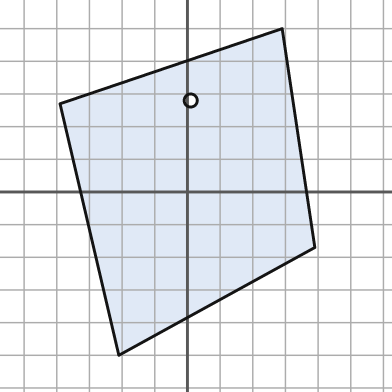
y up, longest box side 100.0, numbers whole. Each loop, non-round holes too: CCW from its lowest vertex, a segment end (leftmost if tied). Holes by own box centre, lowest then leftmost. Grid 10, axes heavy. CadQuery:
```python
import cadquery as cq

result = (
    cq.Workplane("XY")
    .moveTo(-21.0, -50.0)
    .lineTo(39.0, -17.0)
    .lineTo(29.0, 50.0)
    .lineTo(-39.0, 27.0)
    .close()
    .moveTo(1.0, 28.0)
    .circle(2.0)
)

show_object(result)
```